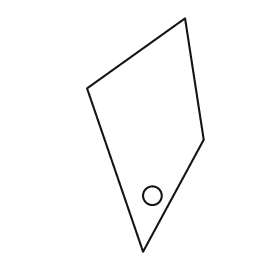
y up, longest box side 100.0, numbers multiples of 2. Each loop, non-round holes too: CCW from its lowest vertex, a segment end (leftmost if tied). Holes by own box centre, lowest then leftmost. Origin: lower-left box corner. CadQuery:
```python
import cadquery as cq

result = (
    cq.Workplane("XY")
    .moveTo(24.0, 0.0)
    .lineTo(50.0, 48.0)
    .lineTo(42.0, 100.0)
    .lineTo(0.0, 70.0)
    .close()
    .moveTo(28.0, 24.0)
    .circle(4.0)
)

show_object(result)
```